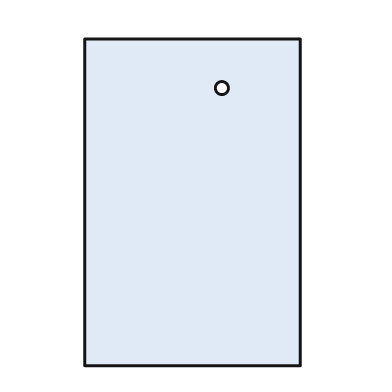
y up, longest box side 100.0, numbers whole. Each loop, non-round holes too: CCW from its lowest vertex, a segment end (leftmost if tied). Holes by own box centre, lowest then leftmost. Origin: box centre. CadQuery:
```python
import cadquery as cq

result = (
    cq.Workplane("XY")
    .moveTo(-33.0, -50.0)
    .lineTo(33.0, -50.0)
    .lineTo(33.0, 50.0)
    .lineTo(-33.0, 50.0)
    .close()
    .moveTo(9.0, 35.0)
    .circle(2.0)
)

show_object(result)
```